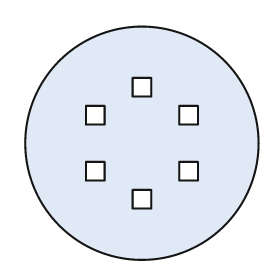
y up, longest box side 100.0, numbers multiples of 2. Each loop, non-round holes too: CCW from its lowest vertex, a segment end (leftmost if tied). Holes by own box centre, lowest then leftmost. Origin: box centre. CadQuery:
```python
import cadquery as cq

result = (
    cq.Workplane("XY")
    .moveTo(0.0, 0.0)
    .circle(50.0)
    .moveTo(-4.0, -28.0)
    .lineTo(4.0, -28.0)
    .lineTo(4.0, -20.0)
    .lineTo(-4.0, -20.0)
    .close()
    .moveTo(-24.0, -16.0)
    .lineTo(-16.0, -16.0)
    .lineTo(-16.0, -8.0)
    .lineTo(-24.0, -8.0)
    .close()
    .moveTo(16.0, -16.0)
    .lineTo(24.0, -16.0)
    .lineTo(24.0, -8.0)
    .lineTo(16.0, -8.0)
    .close()
    .moveTo(-24.0, 8.0)
    .lineTo(-16.0, 8.0)
    .lineTo(-16.0, 16.0)
    .lineTo(-24.0, 16.0)
    .close()
    .moveTo(16.0, 8.0)
    .lineTo(24.0, 8.0)
    .lineTo(24.0, 16.0)
    .lineTo(16.0, 16.0)
    .close()
    .moveTo(-4.0, 20.0)
    .lineTo(4.0, 20.0)
    .lineTo(4.0, 28.0)
    .lineTo(-4.0, 28.0)
    .close()
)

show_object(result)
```